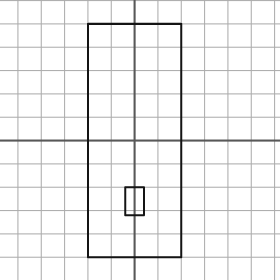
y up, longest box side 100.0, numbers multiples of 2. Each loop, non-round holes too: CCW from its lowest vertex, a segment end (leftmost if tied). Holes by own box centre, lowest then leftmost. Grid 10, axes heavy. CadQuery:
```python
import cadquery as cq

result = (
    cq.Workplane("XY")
    .moveTo(-20.0, -50.0)
    .lineTo(20.0, -50.0)
    .lineTo(20.0, 50.0)
    .lineTo(-20.0, 50.0)
    .close()
    .moveTo(-4.0, -32.0)
    .lineTo(4.0, -32.0)
    .lineTo(4.0, -20.0)
    .lineTo(-4.0, -20.0)
    .close()
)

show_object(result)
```